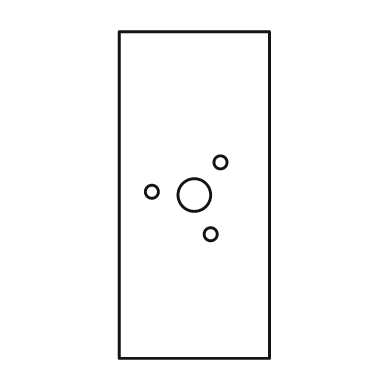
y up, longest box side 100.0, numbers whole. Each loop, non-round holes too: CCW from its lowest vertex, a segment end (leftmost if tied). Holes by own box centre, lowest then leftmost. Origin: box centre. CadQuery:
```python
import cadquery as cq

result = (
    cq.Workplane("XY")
    .moveTo(-23.0, -50.0)
    .lineTo(23.0, -50.0)
    .lineTo(23.0, 50.0)
    .lineTo(-23.0, 50.0)
    .close()
    .moveTo(5.0, -12.0)
    .circle(2.0)
    .moveTo(0.0, 0.0)
    .circle(5.0)
    .moveTo(-13.0, 1.0)
    .circle(2.0)
    .moveTo(8.0, 10.0)
    .circle(2.0)
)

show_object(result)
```